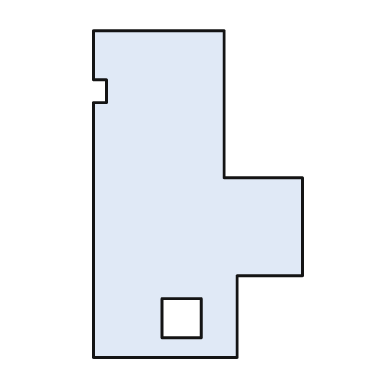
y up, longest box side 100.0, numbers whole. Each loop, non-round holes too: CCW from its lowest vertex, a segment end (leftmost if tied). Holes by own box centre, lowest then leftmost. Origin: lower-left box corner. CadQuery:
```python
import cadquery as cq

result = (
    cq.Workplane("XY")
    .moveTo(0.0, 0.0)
    .lineTo(44.0, 0.0)
    .lineTo(44.0, 25.0)
    .lineTo(64.0, 25.0)
    .lineTo(64.0, 55.0)
    .lineTo(40.0, 55.0)
    .lineTo(40.0, 100.0)
    .lineTo(0.0, 100.0)
    .lineTo(0.0, 85.0)
    .lineTo(4.0, 85.0)
    .lineTo(4.0, 78.0)
    .lineTo(0.0, 78.0)
    .close()
    .moveTo(21.0, 6.0)
    .lineTo(33.0, 6.0)
    .lineTo(33.0, 18.0)
    .lineTo(21.0, 18.0)
    .close()
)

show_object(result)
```